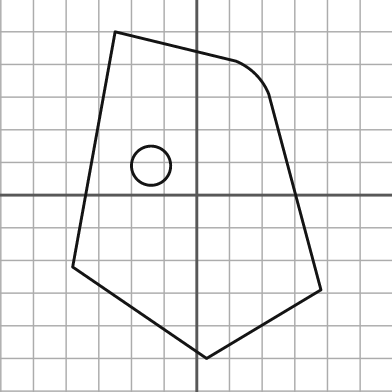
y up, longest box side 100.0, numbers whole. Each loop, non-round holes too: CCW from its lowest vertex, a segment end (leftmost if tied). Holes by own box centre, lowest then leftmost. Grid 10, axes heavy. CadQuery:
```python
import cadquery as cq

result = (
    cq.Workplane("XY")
    .moveTo(3.0, -50.0)
    .lineTo(38.0, -29.0)
    .lineTo(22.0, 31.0)
    .threePointArc((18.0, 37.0), (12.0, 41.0))
    .lineTo(-25.0, 50.0)
    .lineTo(-38.0, -22.0)
    .close()
    .moveTo(-14.0, 9.0)
    .circle(6.0)
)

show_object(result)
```